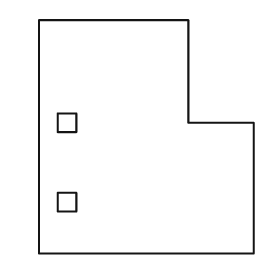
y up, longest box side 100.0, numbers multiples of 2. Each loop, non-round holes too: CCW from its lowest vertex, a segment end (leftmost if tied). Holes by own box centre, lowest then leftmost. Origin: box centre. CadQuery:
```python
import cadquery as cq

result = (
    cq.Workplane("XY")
    .moveTo(-46.0, -50.0)
    .lineTo(46.0, -50.0)
    .lineTo(46.0, 6.0)
    .lineTo(18.0, 6.0)
    .lineTo(18.0, 50.0)
    .lineTo(-46.0, 50.0)
    .close()
    .moveTo(-38.0, -32.0)
    .lineTo(-30.0, -32.0)
    .lineTo(-30.0, -24.0)
    .lineTo(-38.0, -24.0)
    .close()
    .moveTo(-38.0, 2.0)
    .lineTo(-30.0, 2.0)
    .lineTo(-30.0, 10.0)
    .lineTo(-38.0, 10.0)
    .close()
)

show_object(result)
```